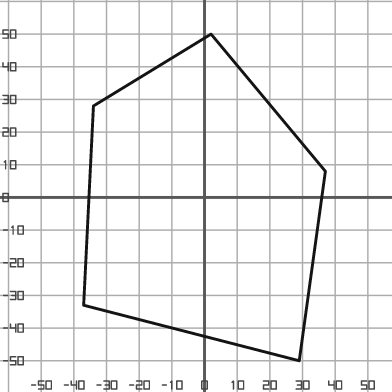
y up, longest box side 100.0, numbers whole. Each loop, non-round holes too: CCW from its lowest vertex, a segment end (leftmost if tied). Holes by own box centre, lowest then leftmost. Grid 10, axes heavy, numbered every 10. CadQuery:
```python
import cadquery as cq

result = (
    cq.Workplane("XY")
    .moveTo(29.0, -50.0)
    .lineTo(37.0, 8.0)
    .lineTo(2.0, 50.0)
    .lineTo(-34.0, 28.0)
    .lineTo(-37.0, -33.0)
    .close()
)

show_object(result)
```